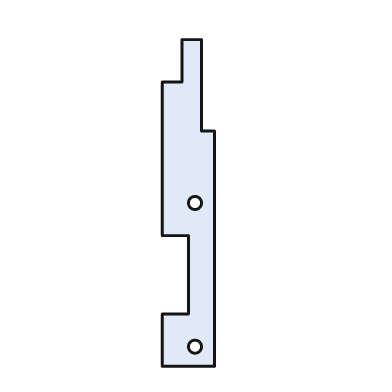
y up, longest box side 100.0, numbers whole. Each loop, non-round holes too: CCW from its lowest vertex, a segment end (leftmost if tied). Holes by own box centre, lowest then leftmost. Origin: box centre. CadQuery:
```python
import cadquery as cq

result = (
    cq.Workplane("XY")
    .moveTo(-8.0, -50.0)
    .lineTo(8.0, -50.0)
    .lineTo(8.0, 22.0)
    .lineTo(4.0, 22.0)
    .lineTo(4.0, 50.0)
    .lineTo(-2.0, 50.0)
    .lineTo(-2.0, 37.0)
    .lineTo(-8.0, 37.0)
    .lineTo(-8.0, -10.0)
    .lineTo(0.0, -10.0)
    .lineTo(0.0, -34.0)
    .lineTo(-8.0, -34.0)
    .close()
    .moveTo(2.0, -44.0)
    .circle(2.0)
    .moveTo(2.0, 0.0)
    .circle(2.0)
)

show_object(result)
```